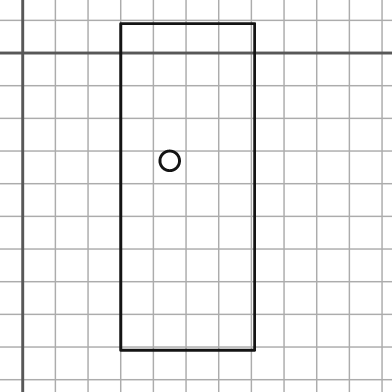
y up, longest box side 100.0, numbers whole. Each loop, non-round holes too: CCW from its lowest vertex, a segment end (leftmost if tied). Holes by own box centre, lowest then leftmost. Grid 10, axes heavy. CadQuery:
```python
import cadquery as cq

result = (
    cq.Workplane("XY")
    .moveTo(30.0, -91.0)
    .lineTo(71.0, -91.0)
    .lineTo(71.0, 9.0)
    .lineTo(30.0, 9.0)
    .close()
    .moveTo(45.0, -33.0)
    .circle(3.0)
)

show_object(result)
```